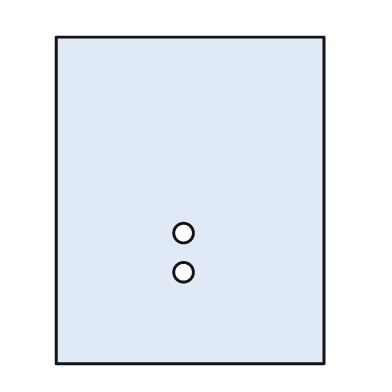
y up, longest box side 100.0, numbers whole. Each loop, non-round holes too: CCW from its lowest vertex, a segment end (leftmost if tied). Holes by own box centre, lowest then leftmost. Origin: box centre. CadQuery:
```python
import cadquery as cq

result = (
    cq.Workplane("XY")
    .moveTo(-41.0, -50.0)
    .lineTo(41.0, -50.0)
    .lineTo(41.0, 50.0)
    .lineTo(-41.0, 50.0)
    .close()
    .moveTo(-2.0, -22.0)
    .circle(3.0)
    .moveTo(-2.0, -10.0)
    .circle(3.0)
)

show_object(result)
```